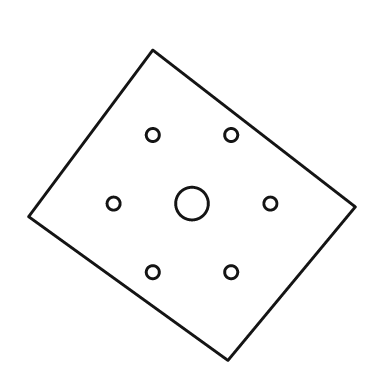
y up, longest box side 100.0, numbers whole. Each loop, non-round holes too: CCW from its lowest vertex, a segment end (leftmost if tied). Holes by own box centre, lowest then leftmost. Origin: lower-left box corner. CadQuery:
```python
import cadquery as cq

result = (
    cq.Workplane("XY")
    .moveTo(61.0, 0.0)
    .lineTo(100.0, 47.0)
    .lineTo(38.0, 95.0)
    .lineTo(0.0, 44.0)
    .close()
    .moveTo(38.0, 27.0)
    .circle(2.0)
    .moveTo(62.0, 27.0)
    .circle(2.0)
    .moveTo(26.0, 48.0)
    .circle(2.0)
    .moveTo(50.0, 48.0)
    .circle(5.0)
    .moveTo(74.0, 48.0)
    .circle(2.0)
    .moveTo(38.0, 69.0)
    .circle(2.0)
    .moveTo(62.0, 69.0)
    .circle(2.0)
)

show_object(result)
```